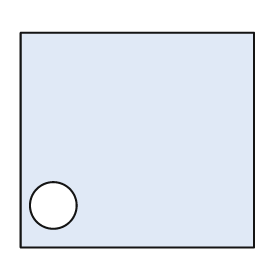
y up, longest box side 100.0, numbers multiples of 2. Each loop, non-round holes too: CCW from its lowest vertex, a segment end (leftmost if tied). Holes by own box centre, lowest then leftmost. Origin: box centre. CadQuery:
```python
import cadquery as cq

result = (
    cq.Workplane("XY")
    .moveTo(-50.0, -46.0)
    .lineTo(50.0, -46.0)
    .lineTo(50.0, 46.0)
    .lineTo(-50.0, 46.0)
    .close()
    .moveTo(-36.0, -28.0)
    .circle(10.0)
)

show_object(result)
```